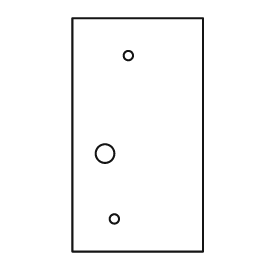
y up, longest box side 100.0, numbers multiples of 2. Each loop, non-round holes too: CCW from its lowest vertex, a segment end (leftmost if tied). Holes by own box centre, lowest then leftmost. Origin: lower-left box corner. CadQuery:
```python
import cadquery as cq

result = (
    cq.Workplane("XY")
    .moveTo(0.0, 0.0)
    .lineTo(56.0, 0.0)
    .lineTo(56.0, 100.0)
    .lineTo(0.0, 100.0)
    .close()
    .moveTo(18.0, 14.0)
    .circle(2.0)
    .moveTo(14.0, 42.0)
    .circle(4.0)
    .moveTo(24.0, 84.0)
    .circle(2.0)
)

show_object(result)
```